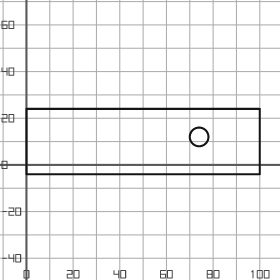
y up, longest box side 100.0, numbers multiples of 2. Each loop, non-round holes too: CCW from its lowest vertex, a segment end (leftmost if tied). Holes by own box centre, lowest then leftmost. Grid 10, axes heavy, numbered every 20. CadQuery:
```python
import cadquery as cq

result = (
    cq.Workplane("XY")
    .moveTo(0.0, -4.0)
    .lineTo(100.0, -4.0)
    .lineTo(100.0, 24.0)
    .lineTo(0.0, 24.0)
    .close()
    .moveTo(74.0, 12.0)
    .circle(4.0)
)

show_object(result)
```